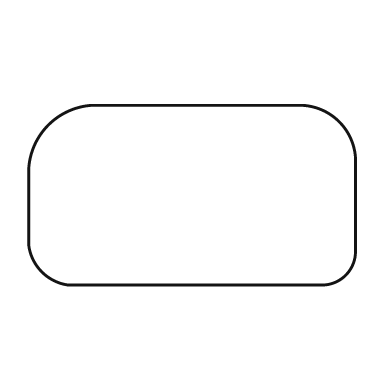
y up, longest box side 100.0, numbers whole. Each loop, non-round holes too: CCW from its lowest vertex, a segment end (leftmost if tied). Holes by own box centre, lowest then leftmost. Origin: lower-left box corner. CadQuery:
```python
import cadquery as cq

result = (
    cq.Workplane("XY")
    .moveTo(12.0, 0.0)
    .lineTo(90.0, 0.0)
    .threePointArc((97.0, 3.0), (100.0, 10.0))
    .lineTo(100.0, 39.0)
    .threePointArc((95.0, 50.0), (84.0, 55.0))
    .lineTo(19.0, 55.0)
    .threePointArc((6.0, 49.0), (0.0, 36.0))
    .lineTo(0.0, 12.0)
    .threePointArc((4.0, 4.0), (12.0, 0.0))
    .close()
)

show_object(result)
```